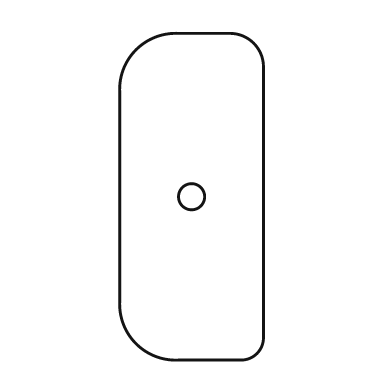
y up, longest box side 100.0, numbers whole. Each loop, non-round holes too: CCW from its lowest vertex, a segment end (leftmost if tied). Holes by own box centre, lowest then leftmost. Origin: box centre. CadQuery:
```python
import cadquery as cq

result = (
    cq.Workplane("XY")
    .moveTo(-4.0, -50.0)
    .lineTo(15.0, -50.0)
    .threePointArc((20.0, -48.0), (22.0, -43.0))
    .lineTo(22.0, 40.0)
    .threePointArc((19.0, 47.0), (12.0, 50.0))
    .lineTo(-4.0, 50.0)
    .threePointArc((-17.0, 45.0), (-22.0, 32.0))
    .lineTo(-22.0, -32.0)
    .threePointArc((-17.0, -45.0), (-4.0, -50.0))
    .close()
    .moveTo(0.0, 0.0)
    .circle(4.0)
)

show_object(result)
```